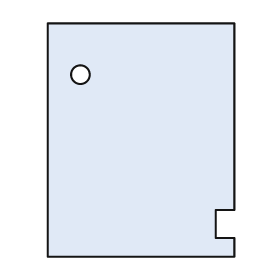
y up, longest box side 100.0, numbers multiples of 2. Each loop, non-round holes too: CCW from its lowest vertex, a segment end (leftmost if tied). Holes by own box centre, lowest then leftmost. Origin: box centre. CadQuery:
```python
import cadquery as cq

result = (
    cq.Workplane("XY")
    .moveTo(-40.0, -50.0)
    .lineTo(40.0, -50.0)
    .lineTo(40.0, -42.0)
    .lineTo(32.0, -42.0)
    .lineTo(32.0, -30.0)
    .lineTo(40.0, -30.0)
    .lineTo(40.0, 50.0)
    .lineTo(-40.0, 50.0)
    .close()
    .moveTo(-26.0, 28.0)
    .circle(4.0)
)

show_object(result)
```